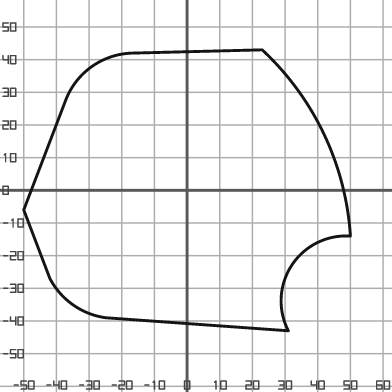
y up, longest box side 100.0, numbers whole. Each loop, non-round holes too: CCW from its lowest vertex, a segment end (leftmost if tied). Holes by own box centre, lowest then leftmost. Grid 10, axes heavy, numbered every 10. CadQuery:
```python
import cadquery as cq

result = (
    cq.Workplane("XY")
    .moveTo(31.0, -43.0)
    .threePointArc((32.0, -23.0), (50.0, -14.0))
    .threePointArc((42.0, 17.0), (23.0, 43.0))
    .lineTo(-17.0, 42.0)
    .threePointArc((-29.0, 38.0), (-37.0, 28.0))
    .lineTo(-50.0, -6.0)
    .lineTo(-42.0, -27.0)
    .threePointArc((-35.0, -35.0), (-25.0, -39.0))
    .close()
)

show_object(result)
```